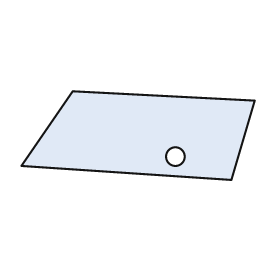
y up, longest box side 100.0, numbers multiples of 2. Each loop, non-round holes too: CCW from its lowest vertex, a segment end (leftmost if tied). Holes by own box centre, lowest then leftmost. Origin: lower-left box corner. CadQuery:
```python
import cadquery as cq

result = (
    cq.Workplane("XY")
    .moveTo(90.0, 0.0)
    .lineTo(100.0, 34.0)
    .lineTo(22.0, 38.0)
    .lineTo(0.0, 6.0)
    .close()
    .moveTo(66.0, 10.0)
    .circle(4.0)
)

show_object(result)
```